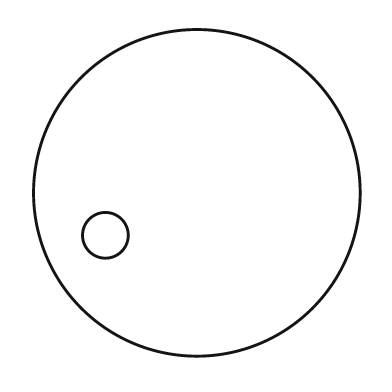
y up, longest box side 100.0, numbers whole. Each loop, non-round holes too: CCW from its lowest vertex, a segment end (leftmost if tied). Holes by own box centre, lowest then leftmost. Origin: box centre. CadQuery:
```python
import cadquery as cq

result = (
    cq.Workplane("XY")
    .moveTo(0.0, 0.0)
    .circle(50.0)
    .moveTo(-28.0, -13.0)
    .circle(7.0)
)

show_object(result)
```